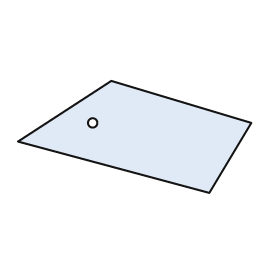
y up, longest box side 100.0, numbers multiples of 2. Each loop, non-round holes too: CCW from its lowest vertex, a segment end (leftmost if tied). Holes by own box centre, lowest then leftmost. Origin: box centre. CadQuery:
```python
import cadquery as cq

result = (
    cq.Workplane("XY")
    .moveTo(32.0, -24.0)
    .lineTo(50.0, 6.0)
    .lineTo(-10.0, 24.0)
    .lineTo(-50.0, -2.0)
    .close()
    .moveTo(-18.0, 6.0)
    .circle(2.0)
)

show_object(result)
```